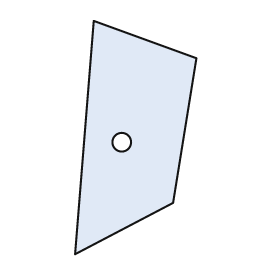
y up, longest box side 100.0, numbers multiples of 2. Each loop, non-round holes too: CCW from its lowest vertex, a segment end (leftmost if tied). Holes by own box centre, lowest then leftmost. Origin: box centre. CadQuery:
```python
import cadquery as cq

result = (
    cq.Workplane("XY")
    .moveTo(-26.0, -50.0)
    .lineTo(16.0, -28.0)
    .lineTo(26.0, 34.0)
    .lineTo(-18.0, 50.0)
    .close()
    .moveTo(-6.0, -2.0)
    .circle(4.0)
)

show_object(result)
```